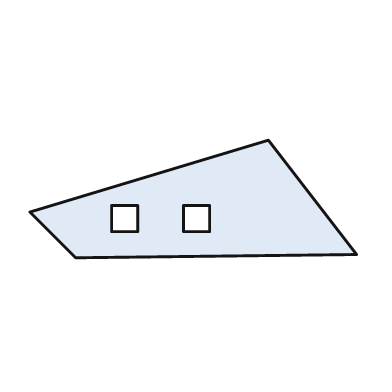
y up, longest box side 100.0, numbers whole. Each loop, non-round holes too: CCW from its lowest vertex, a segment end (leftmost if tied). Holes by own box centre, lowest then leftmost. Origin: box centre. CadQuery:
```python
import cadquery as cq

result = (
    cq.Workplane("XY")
    .moveTo(-36.0, -18.0)
    .lineTo(50.0, -17.0)
    .lineTo(23.0, 18.0)
    .lineTo(-50.0, -4.0)
    .close()
    .moveTo(-25.0, -10.0)
    .lineTo(-17.0, -10.0)
    .lineTo(-17.0, -2.0)
    .lineTo(-25.0, -2.0)
    .close()
    .moveTo(-3.0, -10.0)
    .lineTo(5.0, -10.0)
    .lineTo(5.0, -2.0)
    .lineTo(-3.0, -2.0)
    .close()
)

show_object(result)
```